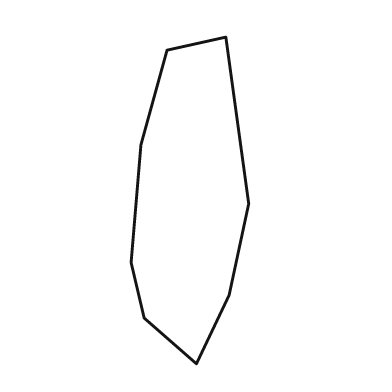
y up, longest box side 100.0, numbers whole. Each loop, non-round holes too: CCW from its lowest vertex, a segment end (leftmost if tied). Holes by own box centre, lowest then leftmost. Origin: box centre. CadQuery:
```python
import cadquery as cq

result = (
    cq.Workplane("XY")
    .moveTo(2.0, -50.0)
    .lineTo(12.0, -29.0)
    .lineTo(18.0, -1.0)
    .lineTo(11.0, 50.0)
    .lineTo(-7.0, 46.0)
    .lineTo(-15.0, 17.0)
    .lineTo(-18.0, -19.0)
    .lineTo(-14.0, -36.0)
    .close()
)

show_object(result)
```